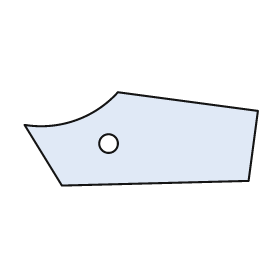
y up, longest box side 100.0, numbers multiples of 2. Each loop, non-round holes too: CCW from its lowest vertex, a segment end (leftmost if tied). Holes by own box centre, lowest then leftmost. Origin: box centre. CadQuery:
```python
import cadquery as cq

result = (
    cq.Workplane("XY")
    .moveTo(-34.0, -20.0)
    .lineTo(46.0, -18.0)
    .lineTo(50.0, 12.0)
    .lineTo(-10.0, 20.0)
    .threePointArc((-28.0, 8.0), (-50.0, 6.0))
    .close()
    .moveTo(-14.0, -2.0)
    .circle(4.0)
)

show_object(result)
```